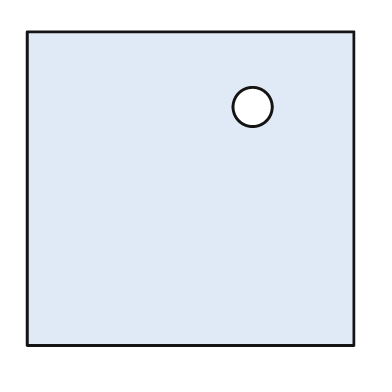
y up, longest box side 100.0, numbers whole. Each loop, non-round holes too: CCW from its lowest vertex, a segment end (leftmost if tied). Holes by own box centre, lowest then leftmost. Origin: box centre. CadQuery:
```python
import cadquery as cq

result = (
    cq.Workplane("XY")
    .moveTo(-50.0, -48.0)
    .lineTo(50.0, -48.0)
    .lineTo(50.0, 48.0)
    .lineTo(-50.0, 48.0)
    .close()
    .moveTo(19.0, 25.0)
    .circle(6.0)
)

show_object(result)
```